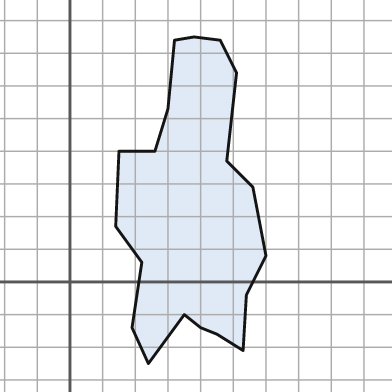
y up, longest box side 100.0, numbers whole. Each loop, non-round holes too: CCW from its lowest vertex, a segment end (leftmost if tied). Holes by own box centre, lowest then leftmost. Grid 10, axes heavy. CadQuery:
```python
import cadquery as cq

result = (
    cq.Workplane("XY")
    .moveTo(24.0, -25.0)
    .lineTo(35.0, -10.0)
    .lineTo(40.0, -14.0)
    .lineTo(45.0, -16.0)
    .lineTo(53.0, -21.0)
    .lineTo(54.0, -4.0)
    .lineTo(60.0, 8.0)
    .lineTo(56.0, 29.0)
    .lineTo(48.0, 37.0)
    .lineTo(51.0, 64.0)
    .lineTo(46.0, 74.0)
    .lineTo(38.0, 75.0)
    .lineTo(32.0, 74.0)
    .lineTo(30.0, 53.0)
    .lineTo(26.0, 40.0)
    .lineTo(15.0, 40.0)
    .lineTo(14.0, 17.0)
    .lineTo(22.0, 6.0)
    .lineTo(19.0, -14.0)
    .close()
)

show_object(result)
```